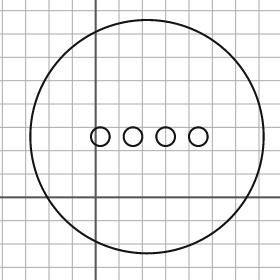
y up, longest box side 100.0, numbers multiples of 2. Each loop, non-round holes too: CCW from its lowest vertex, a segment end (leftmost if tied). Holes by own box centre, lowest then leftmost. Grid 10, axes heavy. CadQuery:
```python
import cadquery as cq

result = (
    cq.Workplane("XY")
    .moveTo(22.0, 26.0)
    .circle(50.0)
    .moveTo(2.0, 26.0)
    .circle(4.0)
    .moveTo(16.0, 26.0)
    .circle(4.0)
    .moveTo(30.0, 26.0)
    .circle(4.0)
    .moveTo(44.0, 26.0)
    .circle(4.0)
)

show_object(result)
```